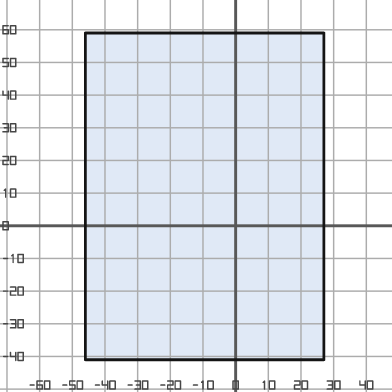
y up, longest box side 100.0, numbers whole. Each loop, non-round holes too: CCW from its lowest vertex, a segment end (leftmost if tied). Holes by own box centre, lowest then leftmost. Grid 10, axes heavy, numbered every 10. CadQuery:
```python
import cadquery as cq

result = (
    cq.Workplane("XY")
    .moveTo(-46.0, -41.0)
    .lineTo(27.0, -41.0)
    .lineTo(27.0, 59.0)
    .lineTo(-46.0, 59.0)
    .close()
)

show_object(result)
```